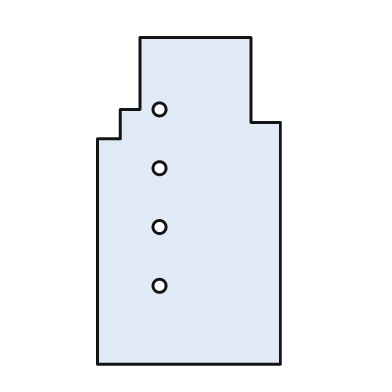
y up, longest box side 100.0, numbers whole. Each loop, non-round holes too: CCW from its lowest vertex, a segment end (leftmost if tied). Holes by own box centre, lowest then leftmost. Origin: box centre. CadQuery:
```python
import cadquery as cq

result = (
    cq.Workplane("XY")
    .moveTo(-28.0, -50.0)
    .lineTo(28.0, -50.0)
    .lineTo(28.0, 24.0)
    .lineTo(19.0, 24.0)
    .lineTo(19.0, 50.0)
    .lineTo(-15.0, 50.0)
    .lineTo(-15.0, 28.0)
    .lineTo(-21.0, 28.0)
    .lineTo(-21.0, 19.0)
    .lineTo(-28.0, 19.0)
    .close()
    .moveTo(-9.0, -26.0)
    .circle(2.0)
    .moveTo(-9.0, -8.0)
    .circle(2.0)
    .moveTo(-9.0, 10.0)
    .circle(2.0)
    .moveTo(-9.0, 28.0)
    .circle(2.0)
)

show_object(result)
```